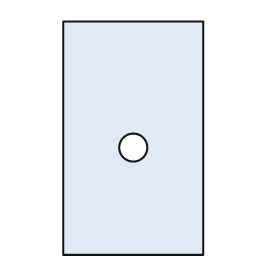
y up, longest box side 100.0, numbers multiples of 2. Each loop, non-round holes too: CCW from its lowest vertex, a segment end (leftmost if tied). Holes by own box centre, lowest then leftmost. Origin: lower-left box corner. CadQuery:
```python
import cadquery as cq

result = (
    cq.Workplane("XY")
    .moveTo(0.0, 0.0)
    .lineTo(60.0, 0.0)
    .lineTo(60.0, 100.0)
    .lineTo(0.0, 100.0)
    .close()
    .moveTo(30.0, 46.0)
    .circle(6.0)
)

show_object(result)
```